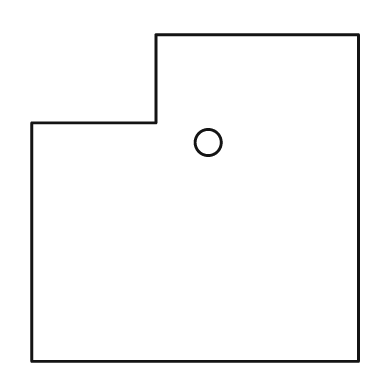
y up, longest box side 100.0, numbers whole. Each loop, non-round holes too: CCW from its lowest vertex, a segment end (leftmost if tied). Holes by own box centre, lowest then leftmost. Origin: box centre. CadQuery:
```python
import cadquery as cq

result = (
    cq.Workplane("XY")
    .moveTo(-50.0, -50.0)
    .lineTo(50.0, -50.0)
    .lineTo(50.0, 50.0)
    .lineTo(-12.0, 50.0)
    .lineTo(-12.0, 23.0)
    .lineTo(-50.0, 23.0)
    .close()
    .moveTo(4.0, 17.0)
    .circle(4.0)
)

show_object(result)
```